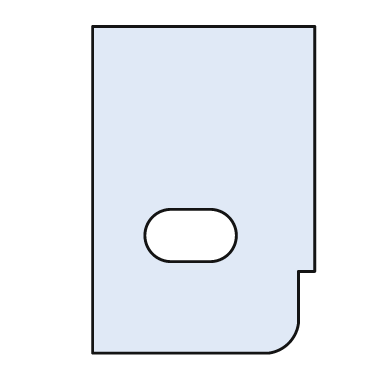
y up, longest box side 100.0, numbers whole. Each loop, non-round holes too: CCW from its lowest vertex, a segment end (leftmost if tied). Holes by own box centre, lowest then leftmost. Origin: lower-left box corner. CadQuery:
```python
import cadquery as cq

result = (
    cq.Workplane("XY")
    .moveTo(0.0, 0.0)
    .lineTo(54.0, 0.0)
    .threePointArc((60.0, 3.0), (63.0, 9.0))
    .lineTo(63.0, 25.0)
    .lineTo(68.0, 25.0)
    .lineTo(68.0, 100.0)
    .lineTo(0.0, 100.0)
    .close()
    .moveTo(24.0, 28.0)
    .lineTo(36.0, 28.0)
    .threePointArc((44.0, 36.0), (36.0, 44.0))
    .lineTo(24.0, 44.0)
    .threePointArc((16.0, 36.0), (24.0, 28.0))
    .close()
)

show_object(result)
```